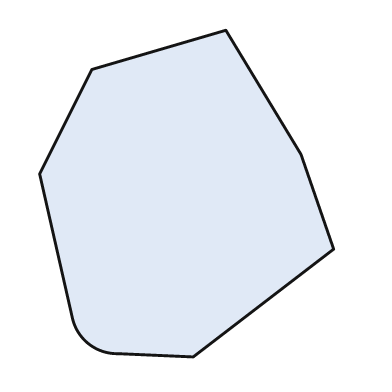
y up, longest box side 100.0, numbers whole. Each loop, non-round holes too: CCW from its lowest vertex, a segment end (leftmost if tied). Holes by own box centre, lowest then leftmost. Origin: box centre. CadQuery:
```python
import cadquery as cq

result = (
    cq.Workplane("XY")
    .moveTo(2.0, -50.0)
    .lineTo(45.0, -17.0)
    .lineTo(35.0, 12.0)
    .lineTo(12.0, 50.0)
    .lineTo(-29.0, 38.0)
    .lineTo(-45.0, 6.0)
    .lineTo(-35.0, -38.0)
    .threePointArc((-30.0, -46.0), (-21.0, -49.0))
    .close()
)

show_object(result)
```